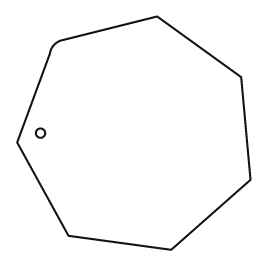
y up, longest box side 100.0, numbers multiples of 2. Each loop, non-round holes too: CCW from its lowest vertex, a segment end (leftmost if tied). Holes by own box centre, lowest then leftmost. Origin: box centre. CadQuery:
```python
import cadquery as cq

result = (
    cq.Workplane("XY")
    .moveTo(16.0, -50.0)
    .lineTo(50.0, -20.0)
    .lineTo(46.0, 24.0)
    .lineTo(10.0, 50.0)
    .lineTo(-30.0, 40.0)
    .threePointArc((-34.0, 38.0), (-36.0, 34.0))
    .lineTo(-50.0, -4.0)
    .lineTo(-28.0, -44.0)
    .close()
    .moveTo(-40.0, 0.0)
    .circle(2.0)
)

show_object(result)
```